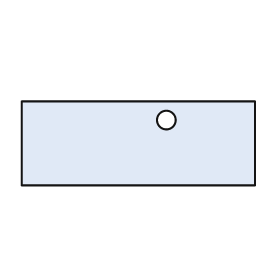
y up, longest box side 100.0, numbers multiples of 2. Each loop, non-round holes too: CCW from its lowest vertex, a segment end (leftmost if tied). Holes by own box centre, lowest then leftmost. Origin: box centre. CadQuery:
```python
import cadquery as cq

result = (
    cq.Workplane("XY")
    .moveTo(-50.0, -18.0)
    .lineTo(50.0, -18.0)
    .lineTo(50.0, 18.0)
    .lineTo(-50.0, 18.0)
    .close()
    .moveTo(12.0, 10.0)
    .circle(4.0)
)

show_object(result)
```